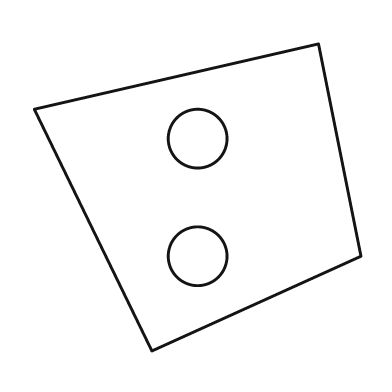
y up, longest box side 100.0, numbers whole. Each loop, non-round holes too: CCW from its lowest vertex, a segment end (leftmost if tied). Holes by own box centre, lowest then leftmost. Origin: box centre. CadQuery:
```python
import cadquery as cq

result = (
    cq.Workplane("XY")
    .moveTo(-14.0, -47.0)
    .lineTo(50.0, -18.0)
    .lineTo(37.0, 47.0)
    .lineTo(-50.0, 27.0)
    .close()
    .moveTo(0.0, -18.0)
    .circle(9.0)
    .moveTo(0.0, 18.0)
    .circle(9.0)
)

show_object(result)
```